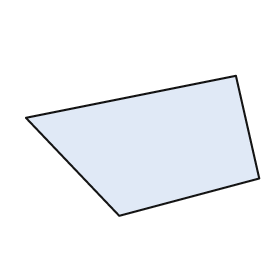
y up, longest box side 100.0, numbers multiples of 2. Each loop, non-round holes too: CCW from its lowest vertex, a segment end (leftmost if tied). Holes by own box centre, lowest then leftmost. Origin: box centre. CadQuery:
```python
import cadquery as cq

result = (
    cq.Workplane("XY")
    .moveTo(-10.0, -30.0)
    .lineTo(50.0, -14.0)
    .lineTo(40.0, 30.0)
    .lineTo(-50.0, 12.0)
    .close()
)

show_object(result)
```